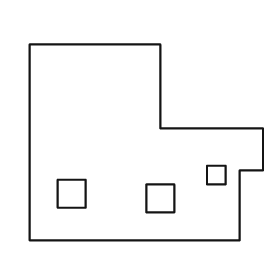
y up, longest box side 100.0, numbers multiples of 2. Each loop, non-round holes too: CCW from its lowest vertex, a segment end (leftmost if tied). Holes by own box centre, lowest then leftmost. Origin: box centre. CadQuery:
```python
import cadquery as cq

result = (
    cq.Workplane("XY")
    .moveTo(-50.0, -42.0)
    .lineTo(40.0, -42.0)
    .lineTo(40.0, -12.0)
    .lineTo(50.0, -12.0)
    .lineTo(50.0, 6.0)
    .lineTo(6.0, 6.0)
    .lineTo(6.0, 42.0)
    .lineTo(-50.0, 42.0)
    .close()
    .moveTo(0.0, -30.0)
    .lineTo(12.0, -30.0)
    .lineTo(12.0, -18.0)
    .lineTo(0.0, -18.0)
    .close()
    .moveTo(-38.0, -28.0)
    .lineTo(-26.0, -28.0)
    .lineTo(-26.0, -16.0)
    .lineTo(-38.0, -16.0)
    .close()
    .moveTo(26.0, -18.0)
    .lineTo(34.0, -18.0)
    .lineTo(34.0, -10.0)
    .lineTo(26.0, -10.0)
    .close()
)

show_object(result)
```